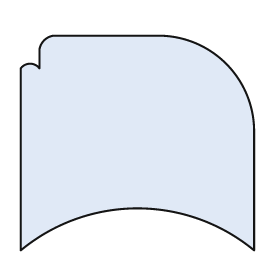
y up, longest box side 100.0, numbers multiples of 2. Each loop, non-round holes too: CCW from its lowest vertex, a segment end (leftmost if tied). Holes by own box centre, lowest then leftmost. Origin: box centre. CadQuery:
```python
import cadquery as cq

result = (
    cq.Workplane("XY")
    .moveTo(-50.0, -46.0)
    .threePointArc((0.0, -28.0), (50.0, -46.0))
    .lineTo(50.0, 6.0)
    .threePointArc((38.0, 34.0), (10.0, 46.0))
    .lineTo(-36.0, 46.0)
    .threePointArc((-40.0, 44.0), (-42.0, 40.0))
    .lineTo(-42.0, 32.0)
    .threePointArc((-46.0, 34.0), (-50.0, 32.0))
    .close()
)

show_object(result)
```